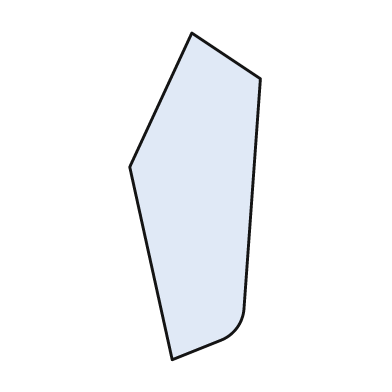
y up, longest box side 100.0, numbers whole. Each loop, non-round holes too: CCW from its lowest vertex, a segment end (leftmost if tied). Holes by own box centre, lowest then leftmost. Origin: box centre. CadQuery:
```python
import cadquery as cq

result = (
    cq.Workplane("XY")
    .moveTo(-7.0, -50.0)
    .lineTo(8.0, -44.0)
    .threePointArc((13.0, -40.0), (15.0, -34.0))
    .lineTo(20.0, 36.0)
    .lineTo(-1.0, 50.0)
    .lineTo(-20.0, 9.0)
    .close()
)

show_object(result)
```